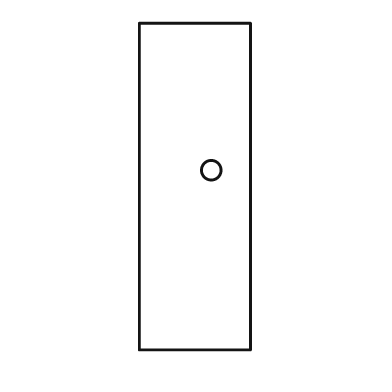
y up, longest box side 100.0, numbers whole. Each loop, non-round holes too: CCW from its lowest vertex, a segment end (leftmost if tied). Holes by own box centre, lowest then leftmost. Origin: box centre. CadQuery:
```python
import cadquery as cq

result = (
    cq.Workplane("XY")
    .moveTo(-17.0, -50.0)
    .lineTo(17.0, -50.0)
    .lineTo(17.0, 50.0)
    .lineTo(-17.0, 50.0)
    .close()
    .moveTo(5.0, 5.0)
    .circle(3.0)
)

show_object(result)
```